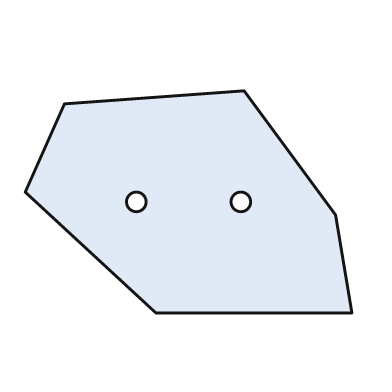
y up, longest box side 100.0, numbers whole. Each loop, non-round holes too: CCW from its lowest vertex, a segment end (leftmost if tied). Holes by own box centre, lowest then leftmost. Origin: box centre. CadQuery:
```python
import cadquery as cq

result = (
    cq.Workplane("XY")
    .moveTo(-10.0, -34.0)
    .lineTo(50.0, -34.0)
    .lineTo(45.0, -4.0)
    .lineTo(17.0, 34.0)
    .lineTo(-38.0, 30.0)
    .lineTo(-50.0, 3.0)
    .close()
    .moveTo(-16.0, 0.0)
    .circle(3.0)
    .moveTo(16.0, 0.0)
    .circle(3.0)
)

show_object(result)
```